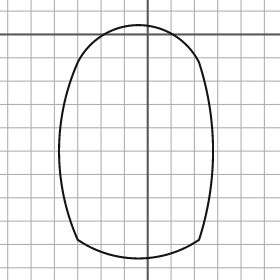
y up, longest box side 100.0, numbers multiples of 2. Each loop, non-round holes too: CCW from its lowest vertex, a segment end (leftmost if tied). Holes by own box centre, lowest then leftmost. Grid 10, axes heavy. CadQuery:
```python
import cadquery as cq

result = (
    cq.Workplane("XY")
    .moveTo(-30.0, -88.0)
    .threePointArc((-4.0, -96.0), (22.0, -88.0))
    .threePointArc((28.0, -50.0), (22.0, -12.0))
    .threePointArc((-4.0, 4.0), (-30.0, -12.0))
    .threePointArc((-38.0, -50.0), (-30.0, -88.0))
    .close()
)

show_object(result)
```